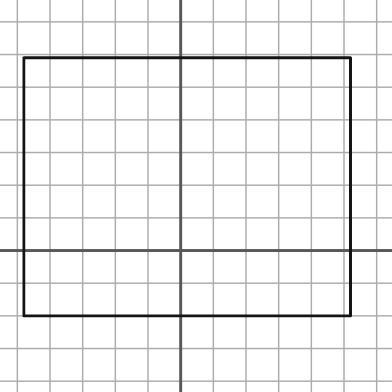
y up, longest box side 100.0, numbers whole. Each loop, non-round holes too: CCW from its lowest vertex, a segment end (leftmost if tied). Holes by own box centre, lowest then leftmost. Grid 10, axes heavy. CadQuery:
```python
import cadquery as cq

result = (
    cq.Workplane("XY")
    .moveTo(-48.0, -20.0)
    .lineTo(52.0, -20.0)
    .lineTo(52.0, 59.0)
    .lineTo(-48.0, 59.0)
    .close()
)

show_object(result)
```